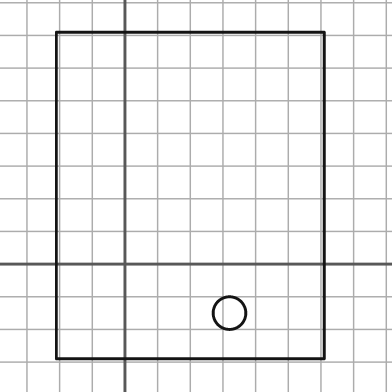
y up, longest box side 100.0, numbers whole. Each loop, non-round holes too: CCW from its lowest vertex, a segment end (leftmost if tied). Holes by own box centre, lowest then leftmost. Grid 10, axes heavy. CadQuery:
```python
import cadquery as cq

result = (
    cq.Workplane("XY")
    .moveTo(-21.0, -29.0)
    .lineTo(61.0, -29.0)
    .lineTo(61.0, 71.0)
    .lineTo(-21.0, 71.0)
    .close()
    .moveTo(32.0, -15.0)
    .circle(5.0)
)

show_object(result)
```